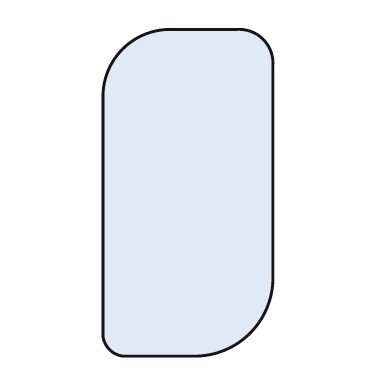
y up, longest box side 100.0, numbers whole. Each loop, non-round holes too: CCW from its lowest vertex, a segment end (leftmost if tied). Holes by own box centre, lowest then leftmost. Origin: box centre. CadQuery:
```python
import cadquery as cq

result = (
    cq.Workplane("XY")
    .moveTo(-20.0, -50.0)
    .lineTo(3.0, -50.0)
    .threePointArc((19.0, -43.0), (26.0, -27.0))
    .lineTo(26.0, 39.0)
    .threePointArc((23.0, 47.0), (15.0, 50.0))
    .lineTo(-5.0, 50.0)
    .threePointArc((-20.0, 44.0), (-26.0, 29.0))
    .lineTo(-26.0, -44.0)
    .threePointArc((-24.0, -48.0), (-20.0, -50.0))
    .close()
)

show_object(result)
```